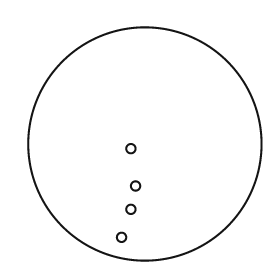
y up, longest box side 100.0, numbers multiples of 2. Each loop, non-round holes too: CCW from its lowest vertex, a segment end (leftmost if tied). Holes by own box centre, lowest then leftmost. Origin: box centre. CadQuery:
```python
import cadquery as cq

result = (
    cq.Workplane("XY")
    .moveTo(0.0, 0.0)
    .circle(50.0)
    .moveTo(-10.0, -40.0)
    .circle(2.0)
    .moveTo(-6.0, -28.0)
    .circle(2.0)
    .moveTo(-4.0, -18.0)
    .circle(2.0)
    .moveTo(-6.0, -2.0)
    .circle(2.0)
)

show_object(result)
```